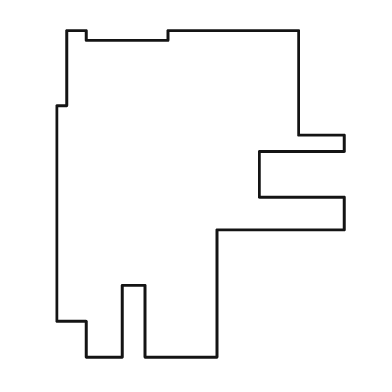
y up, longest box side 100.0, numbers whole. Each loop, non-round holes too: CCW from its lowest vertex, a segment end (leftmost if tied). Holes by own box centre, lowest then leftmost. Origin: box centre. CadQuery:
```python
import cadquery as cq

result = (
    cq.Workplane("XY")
    .moveTo(-35.0, -50.0)
    .lineTo(-24.0, -50.0)
    .lineTo(-24.0, -28.0)
    .lineTo(-17.0, -28.0)
    .lineTo(-17.0, -50.0)
    .lineTo(5.0, -50.0)
    .lineTo(5.0, -11.0)
    .lineTo(44.0, -11.0)
    .lineTo(44.0, -1.0)
    .lineTo(18.0, -1.0)
    .lineTo(18.0, 13.0)
    .lineTo(44.0, 13.0)
    .lineTo(44.0, 18.0)
    .lineTo(30.0, 18.0)
    .lineTo(30.0, 50.0)
    .lineTo(-10.0, 50.0)
    .lineTo(-10.0, 47.0)
    .lineTo(-35.0, 47.0)
    .lineTo(-35.0, 50.0)
    .lineTo(-41.0, 50.0)
    .lineTo(-41.0, 27.0)
    .lineTo(-44.0, 27.0)
    .lineTo(-44.0, -39.0)
    .lineTo(-35.0, -39.0)
    .close()
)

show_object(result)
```